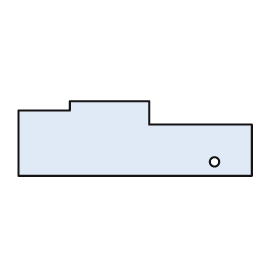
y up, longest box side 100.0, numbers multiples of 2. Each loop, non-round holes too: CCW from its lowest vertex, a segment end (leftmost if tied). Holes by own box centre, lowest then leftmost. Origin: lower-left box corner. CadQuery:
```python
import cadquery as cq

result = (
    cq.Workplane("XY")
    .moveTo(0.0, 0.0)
    .lineTo(100.0, 0.0)
    .lineTo(100.0, 22.0)
    .lineTo(56.0, 22.0)
    .lineTo(56.0, 32.0)
    .lineTo(22.0, 32.0)
    .lineTo(22.0, 28.0)
    .lineTo(0.0, 28.0)
    .close()
    .moveTo(84.0, 6.0)
    .circle(2.0)
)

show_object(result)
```